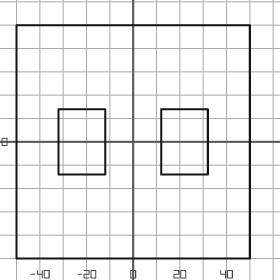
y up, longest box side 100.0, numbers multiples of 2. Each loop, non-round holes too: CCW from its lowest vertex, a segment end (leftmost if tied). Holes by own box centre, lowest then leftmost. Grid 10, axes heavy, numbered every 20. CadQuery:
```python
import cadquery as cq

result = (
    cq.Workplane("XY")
    .moveTo(-50.0, -50.0)
    .lineTo(50.0, -50.0)
    .lineTo(50.0, 50.0)
    .lineTo(-50.0, 50.0)
    .close()
    .moveTo(-32.0, -14.0)
    .lineTo(-12.0, -14.0)
    .lineTo(-12.0, 14.0)
    .lineTo(-32.0, 14.0)
    .close()
    .moveTo(12.0, -14.0)
    .lineTo(32.0, -14.0)
    .lineTo(32.0, 14.0)
    .lineTo(12.0, 14.0)
    .close()
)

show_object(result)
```